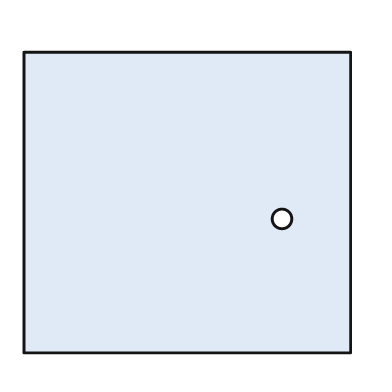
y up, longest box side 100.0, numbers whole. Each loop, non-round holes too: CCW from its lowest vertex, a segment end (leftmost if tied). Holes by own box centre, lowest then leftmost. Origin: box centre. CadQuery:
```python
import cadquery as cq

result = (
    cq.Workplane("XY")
    .moveTo(-50.0, -46.0)
    .lineTo(50.0, -46.0)
    .lineTo(50.0, 46.0)
    .lineTo(-50.0, 46.0)
    .close()
    .moveTo(29.0, -5.0)
    .circle(3.0)
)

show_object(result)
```